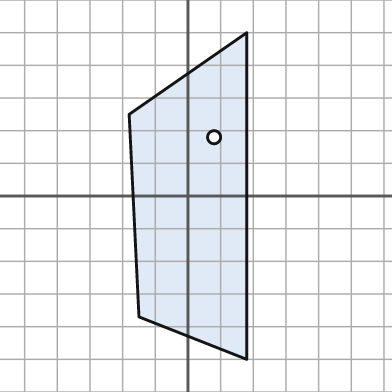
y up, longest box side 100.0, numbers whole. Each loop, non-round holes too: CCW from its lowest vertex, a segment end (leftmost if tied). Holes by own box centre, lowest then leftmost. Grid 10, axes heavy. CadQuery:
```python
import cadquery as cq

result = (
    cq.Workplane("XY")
    .moveTo(18.0, -50.0)
    .lineTo(18.0, 50.0)
    .lineTo(-18.0, 25.0)
    .lineTo(-15.0, -37.0)
    .close()
    .moveTo(8.0, 18.0)
    .circle(2.0)
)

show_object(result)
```